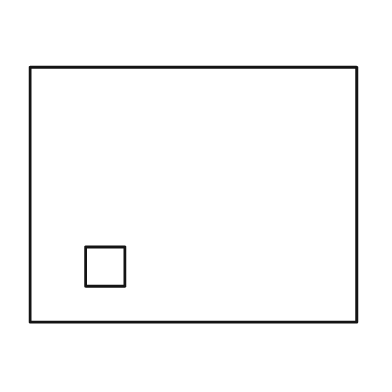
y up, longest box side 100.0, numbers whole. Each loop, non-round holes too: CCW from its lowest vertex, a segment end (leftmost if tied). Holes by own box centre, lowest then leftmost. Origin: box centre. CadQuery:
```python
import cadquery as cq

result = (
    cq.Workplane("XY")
    .moveTo(-50.0, -39.0)
    .lineTo(50.0, -39.0)
    .lineTo(50.0, 39.0)
    .lineTo(-50.0, 39.0)
    .close()
    .moveTo(-33.0, -28.0)
    .lineTo(-21.0, -28.0)
    .lineTo(-21.0, -16.0)
    .lineTo(-33.0, -16.0)
    .close()
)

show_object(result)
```